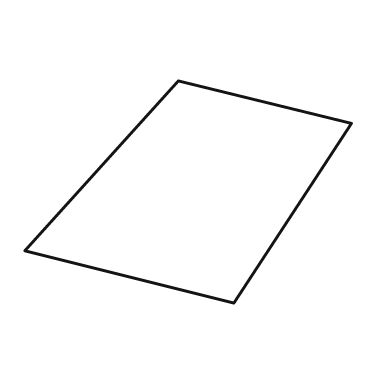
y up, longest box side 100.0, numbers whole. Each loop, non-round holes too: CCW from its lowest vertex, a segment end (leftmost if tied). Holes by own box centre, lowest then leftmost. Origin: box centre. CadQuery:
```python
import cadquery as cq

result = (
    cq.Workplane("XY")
    .moveTo(14.0, -34.0)
    .lineTo(50.0, 21.0)
    .lineTo(-3.0, 34.0)
    .lineTo(-50.0, -18.0)
    .close()
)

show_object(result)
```